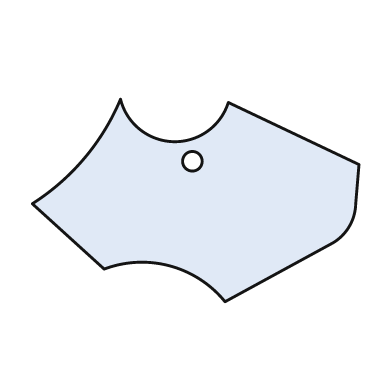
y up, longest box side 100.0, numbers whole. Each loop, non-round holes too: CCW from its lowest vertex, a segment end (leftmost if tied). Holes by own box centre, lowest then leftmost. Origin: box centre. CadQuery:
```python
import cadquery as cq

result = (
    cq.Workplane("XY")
    .moveTo(9.0, -31.0)
    .lineTo(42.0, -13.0)
    .threePointArc((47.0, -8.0), (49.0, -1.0))
    .lineTo(50.0, 11.0)
    .lineTo(10.0, 30.0)
    .threePointArc((-7.0, 18.0), (-23.0, 31.0))
    .threePointArc((-34.0, 13.0), (-50.0, -1.0))
    .lineTo(-28.0, -21.0)
    .threePointArc((-8.0, -20.0), (9.0, -31.0))
    .close()
    .moveTo(-1.0, 12.0)
    .circle(3.0)
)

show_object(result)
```